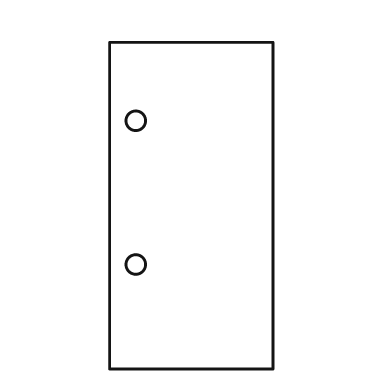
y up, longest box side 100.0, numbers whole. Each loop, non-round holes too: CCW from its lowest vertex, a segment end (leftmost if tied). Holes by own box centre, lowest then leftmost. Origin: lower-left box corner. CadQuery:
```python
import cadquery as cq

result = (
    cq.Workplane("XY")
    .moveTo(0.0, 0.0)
    .lineTo(50.0, 0.0)
    .lineTo(50.0, 100.0)
    .lineTo(0.0, 100.0)
    .close()
    .moveTo(8.0, 32.0)
    .circle(3.0)
    .moveTo(8.0, 76.0)
    .circle(3.0)
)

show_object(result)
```